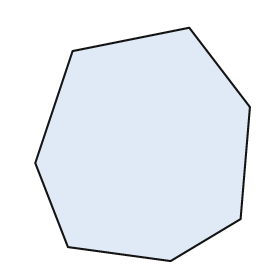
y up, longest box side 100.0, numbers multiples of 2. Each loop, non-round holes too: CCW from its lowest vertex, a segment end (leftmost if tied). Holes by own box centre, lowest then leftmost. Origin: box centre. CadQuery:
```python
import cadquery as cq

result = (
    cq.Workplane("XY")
    .moveTo(12.0, -50.0)
    .lineTo(42.0, -32.0)
    .lineTo(46.0, 16.0)
    .lineTo(20.0, 50.0)
    .lineTo(-30.0, 40.0)
    .lineTo(-46.0, -8.0)
    .lineTo(-32.0, -44.0)
    .close()
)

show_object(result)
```